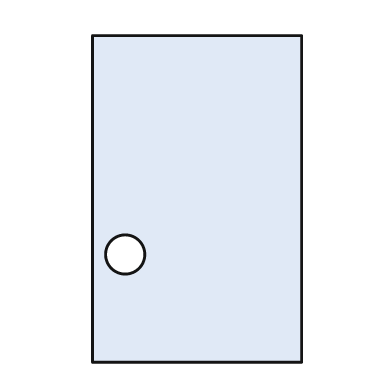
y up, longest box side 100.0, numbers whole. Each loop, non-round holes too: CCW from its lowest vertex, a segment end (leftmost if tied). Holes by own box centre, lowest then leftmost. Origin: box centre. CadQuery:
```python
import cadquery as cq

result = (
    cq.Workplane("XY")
    .moveTo(-32.0, -50.0)
    .lineTo(32.0, -50.0)
    .lineTo(32.0, 50.0)
    .lineTo(-32.0, 50.0)
    .close()
    .moveTo(-22.0, -17.0)
    .circle(6.0)
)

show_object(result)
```